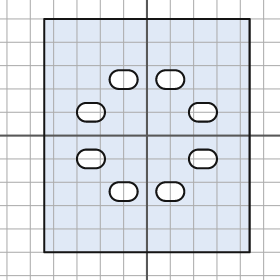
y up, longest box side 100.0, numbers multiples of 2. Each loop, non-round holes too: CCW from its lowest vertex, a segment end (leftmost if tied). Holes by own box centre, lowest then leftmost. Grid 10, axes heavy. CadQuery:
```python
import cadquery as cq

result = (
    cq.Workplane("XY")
    .moveTo(-44.0, -50.0)
    .lineTo(44.0, -50.0)
    .lineTo(44.0, 50.0)
    .lineTo(-44.0, 50.0)
    .close()
    .moveTo(-12.0, -28.0)
    .lineTo(-8.0, -28.0)
    .threePointArc((-4.0, -24.0), (-8.0, -20.0))
    .lineTo(-12.0, -20.0)
    .threePointArc((-16.0, -24.0), (-12.0, -28.0))
    .close()
    .moveTo(8.0, -28.0)
    .lineTo(12.0, -28.0)
    .threePointArc((16.0, -24.0), (12.0, -20.0))
    .lineTo(8.0, -20.0)
    .threePointArc((4.0, -24.0), (8.0, -28.0))
    .close()
    .moveTo(-26.0, -14.0)
    .lineTo(-22.0, -14.0)
    .threePointArc((-18.0, -10.0), (-22.0, -6.0))
    .lineTo(-26.0, -6.0)
    .threePointArc((-30.0, -10.0), (-26.0, -14.0))
    .close()
    .moveTo(22.0, -14.0)
    .lineTo(26.0, -14.0)
    .threePointArc((30.0, -10.0), (26.0, -6.0))
    .lineTo(22.0, -6.0)
    .threePointArc((18.0, -10.0), (22.0, -14.0))
    .close()
    .moveTo(-26.0, 6.0)
    .lineTo(-22.0, 6.0)
    .threePointArc((-18.0, 10.0), (-22.0, 14.0))
    .lineTo(-26.0, 14.0)
    .threePointArc((-30.0, 10.0), (-26.0, 6.0))
    .close()
    .moveTo(22.0, 6.0)
    .lineTo(26.0, 6.0)
    .threePointArc((30.0, 10.0), (26.0, 14.0))
    .lineTo(22.0, 14.0)
    .threePointArc((18.0, 10.0), (22.0, 6.0))
    .close()
    .moveTo(-12.0, 20.0)
    .lineTo(-8.0, 20.0)
    .threePointArc((-4.0, 24.0), (-8.0, 28.0))
    .lineTo(-12.0, 28.0)
    .threePointArc((-16.0, 24.0), (-12.0, 20.0))
    .close()
    .moveTo(8.0, 20.0)
    .lineTo(12.0, 20.0)
    .threePointArc((16.0, 24.0), (12.0, 28.0))
    .lineTo(8.0, 28.0)
    .threePointArc((4.0, 24.0), (8.0, 20.0))
    .close()
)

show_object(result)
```